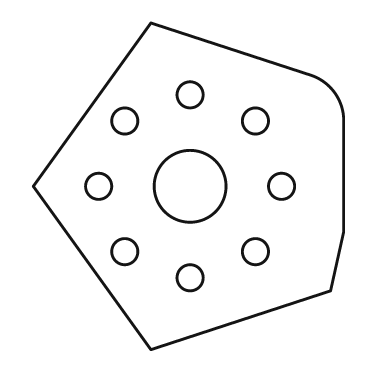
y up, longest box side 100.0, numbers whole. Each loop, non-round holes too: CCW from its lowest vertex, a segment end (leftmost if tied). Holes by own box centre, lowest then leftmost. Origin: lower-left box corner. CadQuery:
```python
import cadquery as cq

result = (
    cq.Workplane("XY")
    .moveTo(36.0, 0.0)
    .lineTo(91.0, 18.0)
    .lineTo(95.0, 36.0)
    .lineTo(95.0, 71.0)
    .threePointArc((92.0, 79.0), (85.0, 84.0))
    .lineTo(36.0, 100.0)
    .lineTo(0.0, 50.0)
    .close()
    .moveTo(48.0, 22.0)
    .circle(4.0)
    .moveTo(28.0, 30.0)
    .circle(4.0)
    .moveTo(68.0, 30.0)
    .circle(4.0)
    .moveTo(20.0, 50.0)
    .circle(4.0)
    .moveTo(48.0, 50.0)
    .circle(11.0)
    .moveTo(76.0, 50.0)
    .circle(4.0)
    .moveTo(28.0, 70.0)
    .circle(4.0)
    .moveTo(68.0, 70.0)
    .circle(4.0)
    .moveTo(48.0, 78.0)
    .circle(4.0)
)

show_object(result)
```